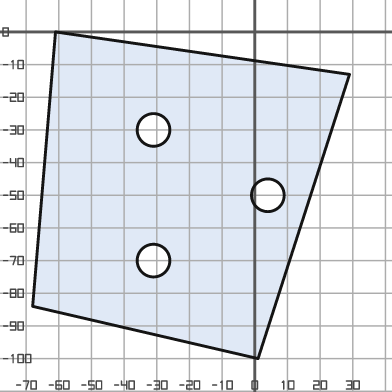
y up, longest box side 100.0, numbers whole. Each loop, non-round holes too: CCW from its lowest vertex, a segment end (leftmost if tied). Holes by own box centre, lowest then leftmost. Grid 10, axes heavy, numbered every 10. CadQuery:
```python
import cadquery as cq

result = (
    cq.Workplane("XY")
    .moveTo(1.0, -100.0)
    .lineTo(29.0, -13.0)
    .lineTo(-61.0, 0.0)
    .lineTo(-68.0, -84.0)
    .close()
    .moveTo(-31.0, -70.0)
    .circle(5.0)
    .moveTo(4.0, -50.0)
    .circle(5.0)
    .moveTo(-31.0, -30.0)
    .circle(5.0)
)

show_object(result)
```